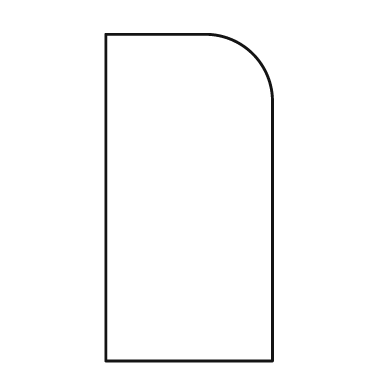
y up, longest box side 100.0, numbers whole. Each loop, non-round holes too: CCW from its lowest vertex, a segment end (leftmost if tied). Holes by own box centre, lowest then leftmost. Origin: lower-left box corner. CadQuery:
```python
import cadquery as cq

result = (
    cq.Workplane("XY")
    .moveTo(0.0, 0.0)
    .lineTo(51.0, 0.0)
    .lineTo(51.0, 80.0)
    .threePointArc((45.0, 94.0), (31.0, 100.0))
    .lineTo(0.0, 100.0)
    .close()
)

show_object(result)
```